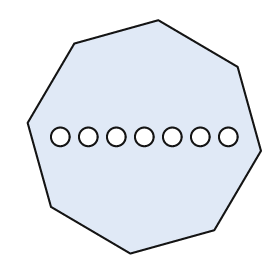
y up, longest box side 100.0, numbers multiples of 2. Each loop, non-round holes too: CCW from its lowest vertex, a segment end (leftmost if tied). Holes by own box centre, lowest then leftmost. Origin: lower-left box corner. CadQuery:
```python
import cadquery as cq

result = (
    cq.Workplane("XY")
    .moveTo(44.0, 0.0)
    .lineTo(80.0, 10.0)
    .lineTo(100.0, 44.0)
    .lineTo(90.0, 80.0)
    .lineTo(56.0, 100.0)
    .lineTo(20.0, 90.0)
    .lineTo(0.0, 56.0)
    .lineTo(10.0, 20.0)
    .close()
    .moveTo(14.0, 50.0)
    .circle(4.0)
    .moveTo(26.0, 50.0)
    .circle(4.0)
    .moveTo(38.0, 50.0)
    .circle(4.0)
    .moveTo(50.0, 50.0)
    .circle(4.0)
    .moveTo(62.0, 50.0)
    .circle(4.0)
    .moveTo(74.0, 50.0)
    .circle(4.0)
    .moveTo(86.0, 50.0)
    .circle(4.0)
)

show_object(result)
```